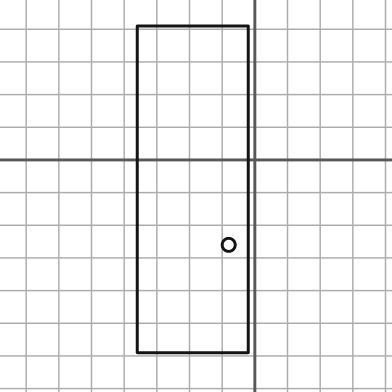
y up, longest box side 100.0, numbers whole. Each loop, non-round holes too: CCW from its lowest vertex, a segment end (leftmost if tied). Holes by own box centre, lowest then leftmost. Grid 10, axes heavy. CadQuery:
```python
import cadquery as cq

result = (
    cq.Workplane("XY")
    .moveTo(-36.0, -59.0)
    .lineTo(-2.0, -59.0)
    .lineTo(-2.0, 41.0)
    .lineTo(-36.0, 41.0)
    .close()
    .moveTo(-8.0, -26.0)
    .circle(2.0)
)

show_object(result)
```